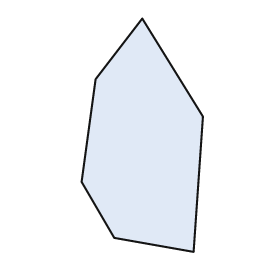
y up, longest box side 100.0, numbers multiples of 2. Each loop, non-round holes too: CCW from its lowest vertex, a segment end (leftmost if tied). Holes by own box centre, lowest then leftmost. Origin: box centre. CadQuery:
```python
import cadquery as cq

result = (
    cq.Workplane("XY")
    .moveTo(22.0, -50.0)
    .lineTo(26.0, 8.0)
    .lineTo(0.0, 50.0)
    .lineTo(-20.0, 24.0)
    .lineTo(-26.0, -20.0)
    .lineTo(-12.0, -44.0)
    .close()
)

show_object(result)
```